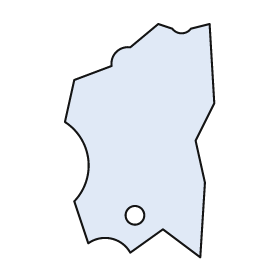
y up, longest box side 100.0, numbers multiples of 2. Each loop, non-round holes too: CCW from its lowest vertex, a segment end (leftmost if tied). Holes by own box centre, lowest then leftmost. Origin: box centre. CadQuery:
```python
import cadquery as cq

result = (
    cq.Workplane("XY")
    .moveTo(26.0, -50.0)
    .lineTo(28.0, -18.0)
    .lineTo(24.0, 0.0)
    .lineTo(32.0, 16.0)
    .lineTo(30.0, 50.0)
    .lineTo(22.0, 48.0)
    .threePointArc((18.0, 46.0), (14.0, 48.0))
    .lineTo(8.0, 50.0)
    .lineTo(-4.0, 40.0)
    .threePointArc((-10.0, 38.0), (-12.0, 32.0))
    .lineTo(-28.0, 26.0)
    .lineTo(-32.0, 8.0)
    .threePointArc((-22.0, -8.0), (-28.0, -26.0))
    .lineTo(-22.0, -44.0)
    .threePointArc((-12.0, -42.0), (-4.0, -48.0))
    .lineTo(10.0, -38.0)
    .close()
    .moveTo(-2.0, -32.0)
    .circle(4.0)
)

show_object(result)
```